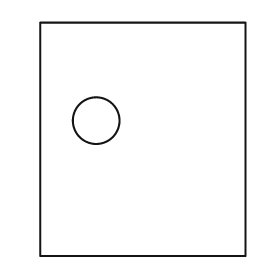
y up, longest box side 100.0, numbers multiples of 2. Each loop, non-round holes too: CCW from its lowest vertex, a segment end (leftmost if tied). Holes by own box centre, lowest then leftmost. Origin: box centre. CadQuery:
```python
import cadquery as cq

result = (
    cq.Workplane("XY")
    .moveTo(-44.0, -50.0)
    .lineTo(44.0, -50.0)
    .lineTo(44.0, 50.0)
    .lineTo(-44.0, 50.0)
    .close()
    .moveTo(-20.0, 8.0)
    .circle(10.0)
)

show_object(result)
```